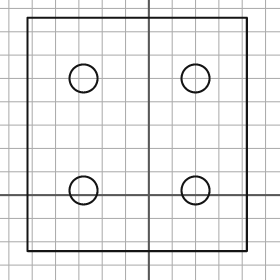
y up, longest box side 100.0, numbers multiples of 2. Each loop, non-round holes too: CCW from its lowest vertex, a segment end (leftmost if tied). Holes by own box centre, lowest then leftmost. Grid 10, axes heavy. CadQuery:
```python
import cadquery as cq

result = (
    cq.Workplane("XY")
    .moveTo(-52.0, -24.0)
    .lineTo(42.0, -24.0)
    .lineTo(42.0, 76.0)
    .lineTo(-52.0, 76.0)
    .close()
    .moveTo(-28.0, 2.0)
    .circle(6.0)
    .moveTo(20.0, 2.0)
    .circle(6.0)
    .moveTo(-28.0, 50.0)
    .circle(6.0)
    .moveTo(20.0, 50.0)
    .circle(6.0)
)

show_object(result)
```